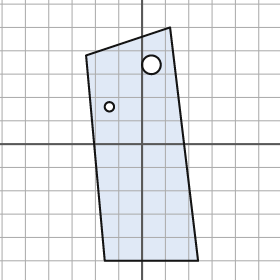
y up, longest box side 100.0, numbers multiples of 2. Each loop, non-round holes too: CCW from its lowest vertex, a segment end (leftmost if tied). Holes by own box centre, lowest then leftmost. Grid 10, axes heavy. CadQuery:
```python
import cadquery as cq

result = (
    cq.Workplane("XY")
    .moveTo(-16.0, -50.0)
    .lineTo(24.0, -50.0)
    .lineTo(12.0, 50.0)
    .lineTo(-24.0, 38.0)
    .close()
    .moveTo(-14.0, 16.0)
    .circle(2.0)
    .moveTo(4.0, 34.0)
    .circle(4.0)
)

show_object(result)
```